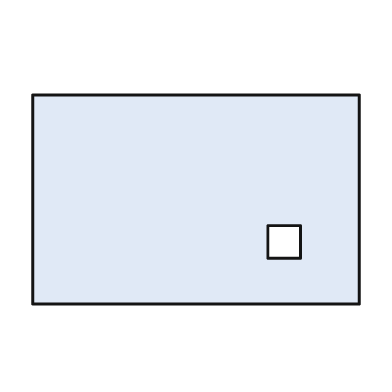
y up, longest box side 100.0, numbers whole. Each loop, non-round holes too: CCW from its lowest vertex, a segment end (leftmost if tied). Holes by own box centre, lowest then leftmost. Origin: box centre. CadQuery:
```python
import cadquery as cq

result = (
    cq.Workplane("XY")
    .moveTo(-50.0, -32.0)
    .lineTo(50.0, -32.0)
    .lineTo(50.0, 32.0)
    .lineTo(-50.0, 32.0)
    .close()
    .moveTo(22.0, -18.0)
    .lineTo(32.0, -18.0)
    .lineTo(32.0, -8.0)
    .lineTo(22.0, -8.0)
    .close()
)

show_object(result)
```